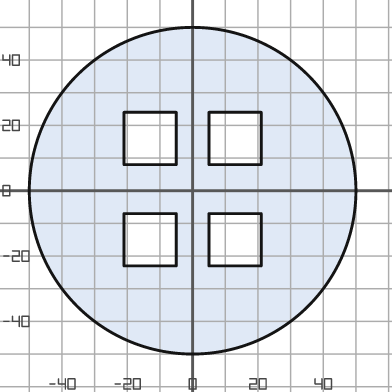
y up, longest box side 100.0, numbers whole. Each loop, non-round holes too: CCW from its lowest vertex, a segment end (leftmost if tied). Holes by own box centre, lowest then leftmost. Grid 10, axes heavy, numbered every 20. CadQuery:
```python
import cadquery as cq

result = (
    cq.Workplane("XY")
    .moveTo(0.0, 0.0)
    .circle(50.0)
    .moveTo(-21.0, -23.0)
    .lineTo(-5.0, -23.0)
    .lineTo(-5.0, -7.0)
    .lineTo(-21.0, -7.0)
    .close()
    .moveTo(5.0, -23.0)
    .lineTo(21.0, -23.0)
    .lineTo(21.0, -7.0)
    .lineTo(5.0, -7.0)
    .close()
    .moveTo(-21.0, 8.0)
    .lineTo(-5.0, 8.0)
    .lineTo(-5.0, 24.0)
    .lineTo(-21.0, 24.0)
    .close()
    .moveTo(5.0, 8.0)
    .lineTo(21.0, 8.0)
    .lineTo(21.0, 24.0)
    .lineTo(5.0, 24.0)
    .close()
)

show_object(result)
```